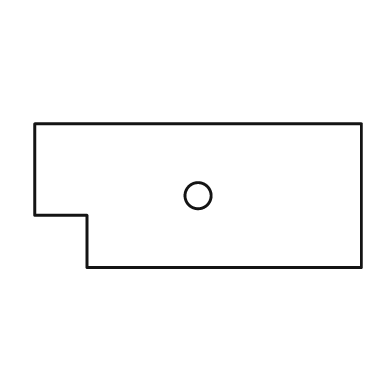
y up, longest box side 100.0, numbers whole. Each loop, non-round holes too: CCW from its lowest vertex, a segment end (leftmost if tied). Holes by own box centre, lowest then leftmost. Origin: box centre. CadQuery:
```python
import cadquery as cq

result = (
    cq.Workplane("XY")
    .moveTo(-34.0, -22.0)
    .lineTo(50.0, -22.0)
    .lineTo(50.0, 22.0)
    .lineTo(-50.0, 22.0)
    .lineTo(-50.0, -6.0)
    .lineTo(-34.0, -6.0)
    .close()
    .moveTo(0.0, 0.0)
    .circle(4.0)
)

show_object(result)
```